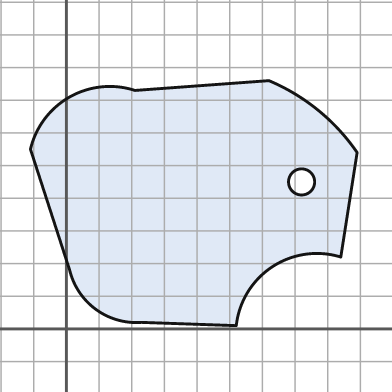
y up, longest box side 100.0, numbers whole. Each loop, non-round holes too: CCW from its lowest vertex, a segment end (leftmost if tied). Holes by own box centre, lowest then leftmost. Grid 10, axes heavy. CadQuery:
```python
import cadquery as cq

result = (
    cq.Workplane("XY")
    .moveTo(52.0, 1.0)
    .threePointArc((63.0, 19.0), (84.0, 22.0))
    .lineTo(89.0, 54.0)
    .threePointArc((77.0, 67.0), (62.0, 76.0))
    .lineTo(21.0, 73.0)
    .threePointArc((1.0, 71.0), (-11.0, 55.0))
    .lineTo(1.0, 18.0)
    .threePointArc((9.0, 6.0), (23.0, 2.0))
    .close()
    .moveTo(72.0, 45.0)
    .circle(4.0)
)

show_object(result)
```